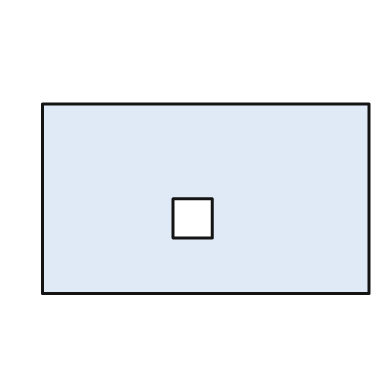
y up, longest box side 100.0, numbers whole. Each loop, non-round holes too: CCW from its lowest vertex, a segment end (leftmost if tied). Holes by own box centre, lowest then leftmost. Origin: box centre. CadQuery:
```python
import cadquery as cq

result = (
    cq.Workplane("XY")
    .moveTo(-50.0, -29.0)
    .lineTo(50.0, -29.0)
    .lineTo(50.0, 29.0)
    .lineTo(-50.0, 29.0)
    .close()
    .moveTo(-10.0, -12.0)
    .lineTo(2.0, -12.0)
    .lineTo(2.0, 0.0)
    .lineTo(-10.0, 0.0)
    .close()
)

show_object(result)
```